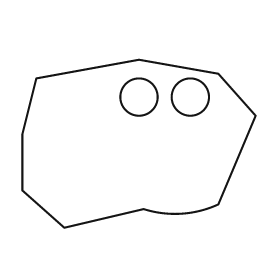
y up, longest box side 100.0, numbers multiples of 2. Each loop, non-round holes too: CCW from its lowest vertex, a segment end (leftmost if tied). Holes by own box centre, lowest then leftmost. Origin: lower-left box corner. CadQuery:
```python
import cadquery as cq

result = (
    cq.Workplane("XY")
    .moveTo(18.0, 0.0)
    .lineTo(52.0, 8.0)
    .threePointArc((68.0, 6.0), (84.0, 10.0))
    .lineTo(100.0, 48.0)
    .lineTo(84.0, 66.0)
    .lineTo(50.0, 72.0)
    .lineTo(6.0, 64.0)
    .lineTo(0.0, 40.0)
    .lineTo(0.0, 16.0)
    .close()
    .moveTo(50.0, 56.0)
    .circle(8.0)
    .moveTo(72.0, 56.0)
    .circle(8.0)
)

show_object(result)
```